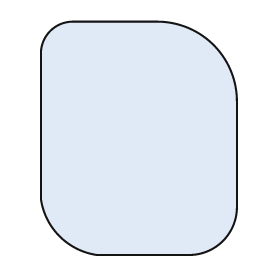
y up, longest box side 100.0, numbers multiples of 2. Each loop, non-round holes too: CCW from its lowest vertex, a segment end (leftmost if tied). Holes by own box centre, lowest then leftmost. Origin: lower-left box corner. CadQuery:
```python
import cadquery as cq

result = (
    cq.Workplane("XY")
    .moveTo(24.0, 0.0)
    .lineTo(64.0, 0.0)
    .threePointArc((78.0, 6.0), (84.0, 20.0))
    .lineTo(84.0, 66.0)
    .threePointArc((74.0, 90.0), (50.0, 100.0))
    .lineTo(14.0, 100.0)
    .threePointArc((4.0, 96.0), (0.0, 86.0))
    .lineTo(0.0, 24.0)
    .threePointArc((8.0, 8.0), (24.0, 0.0))
    .close()
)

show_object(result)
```